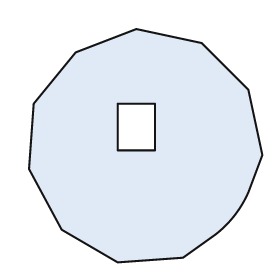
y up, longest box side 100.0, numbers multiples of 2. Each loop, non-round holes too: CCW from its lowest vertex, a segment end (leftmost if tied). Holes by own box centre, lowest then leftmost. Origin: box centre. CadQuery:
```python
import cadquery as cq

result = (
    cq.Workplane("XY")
    .moveTo(-12.0, -50.0)
    .lineTo(16.0, -48.0)
    .lineTo(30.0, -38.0)
    .threePointArc((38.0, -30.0), (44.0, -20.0))
    .lineTo(50.0, -4.0)
    .lineTo(44.0, 24.0)
    .lineTo(24.0, 44.0)
    .lineTo(-4.0, 50.0)
    .lineTo(-30.0, 40.0)
    .lineTo(-48.0, 18.0)
    .lineTo(-50.0, -10.0)
    .lineTo(-36.0, -36.0)
    .close()
    .moveTo(-12.0, -2.0)
    .lineTo(4.0, -2.0)
    .lineTo(4.0, 18.0)
    .lineTo(-12.0, 18.0)
    .close()
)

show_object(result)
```